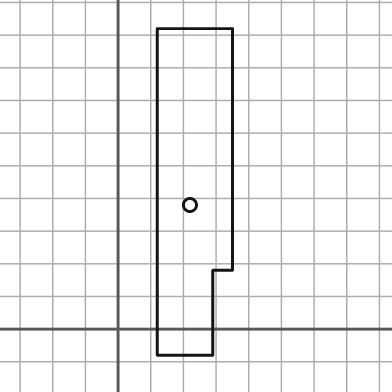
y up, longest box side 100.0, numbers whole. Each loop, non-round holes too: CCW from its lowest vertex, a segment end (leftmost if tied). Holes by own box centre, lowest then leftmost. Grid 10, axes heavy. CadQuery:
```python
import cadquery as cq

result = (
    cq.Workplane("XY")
    .moveTo(12.0, -8.0)
    .lineTo(29.0, -8.0)
    .lineTo(29.0, 18.0)
    .lineTo(35.0, 18.0)
    .lineTo(35.0, 92.0)
    .lineTo(12.0, 92.0)
    .close()
    .moveTo(22.0, 38.0)
    .circle(2.0)
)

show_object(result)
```